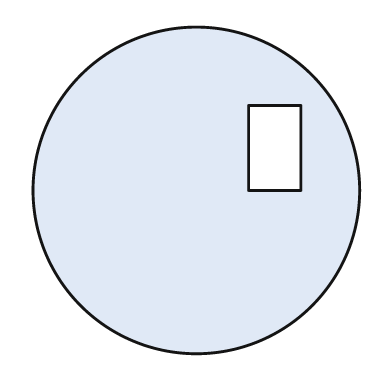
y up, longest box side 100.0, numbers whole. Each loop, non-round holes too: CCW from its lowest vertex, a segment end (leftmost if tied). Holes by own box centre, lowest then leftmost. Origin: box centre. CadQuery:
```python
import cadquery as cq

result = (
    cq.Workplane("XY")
    .moveTo(0.0, 0.0)
    .circle(50.0)
    .moveTo(16.0, 0.0)
    .lineTo(32.0, 0.0)
    .lineTo(32.0, 26.0)
    .lineTo(16.0, 26.0)
    .close()
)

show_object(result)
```